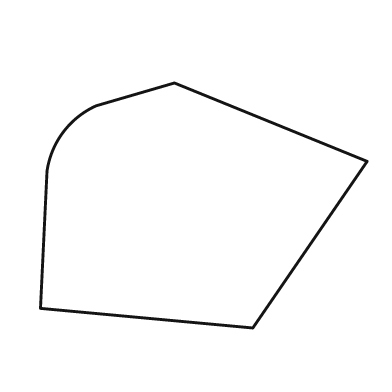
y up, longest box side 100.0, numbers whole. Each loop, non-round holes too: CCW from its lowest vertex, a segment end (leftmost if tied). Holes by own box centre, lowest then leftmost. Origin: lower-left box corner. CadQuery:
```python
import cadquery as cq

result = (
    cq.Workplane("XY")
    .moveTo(65.0, 0.0)
    .lineTo(100.0, 51.0)
    .lineTo(41.0, 75.0)
    .lineTo(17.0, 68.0)
    .threePointArc((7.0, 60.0), (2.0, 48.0))
    .lineTo(0.0, 6.0)
    .close()
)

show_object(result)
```